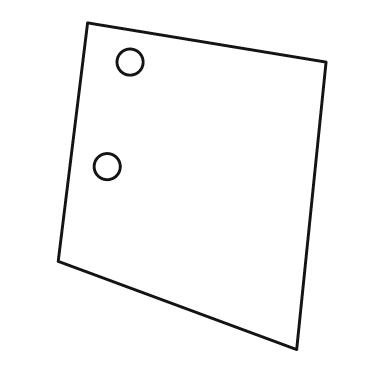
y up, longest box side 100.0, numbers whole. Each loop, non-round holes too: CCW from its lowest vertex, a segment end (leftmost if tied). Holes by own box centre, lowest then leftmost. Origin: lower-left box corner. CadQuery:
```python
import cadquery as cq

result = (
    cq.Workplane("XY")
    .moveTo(73.0, 0.0)
    .lineTo(82.0, 88.0)
    .lineTo(9.0, 100.0)
    .lineTo(0.0, 27.0)
    .close()
    .moveTo(15.0, 56.0)
    .circle(4.0)
    .moveTo(22.0, 88.0)
    .circle(4.0)
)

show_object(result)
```